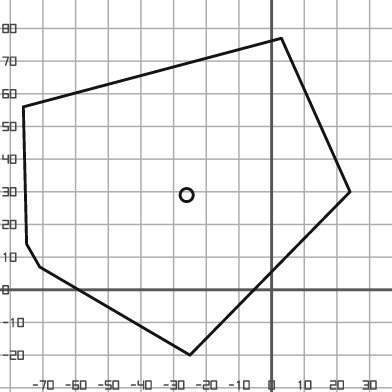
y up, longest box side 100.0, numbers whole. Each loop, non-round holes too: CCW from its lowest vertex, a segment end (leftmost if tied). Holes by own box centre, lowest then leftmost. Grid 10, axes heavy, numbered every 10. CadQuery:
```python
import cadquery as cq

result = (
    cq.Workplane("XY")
    .moveTo(-25.0, -20.0)
    .lineTo(24.0, 30.0)
    .lineTo(3.0, 77.0)
    .lineTo(-76.0, 56.0)
    .lineTo(-75.0, 14.0)
    .lineTo(-71.0, 7.0)
    .close()
    .moveTo(-26.0, 29.0)
    .circle(2.0)
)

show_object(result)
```